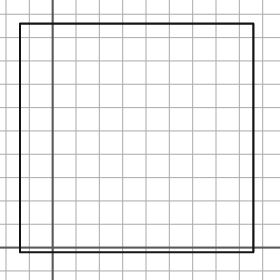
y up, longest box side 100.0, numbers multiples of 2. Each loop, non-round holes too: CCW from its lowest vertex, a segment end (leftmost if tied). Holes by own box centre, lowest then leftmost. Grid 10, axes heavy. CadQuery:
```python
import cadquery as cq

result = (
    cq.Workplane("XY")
    .moveTo(-14.0, -2.0)
    .lineTo(86.0, -2.0)
    .lineTo(86.0, 96.0)
    .lineTo(-14.0, 96.0)
    .close()
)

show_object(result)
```